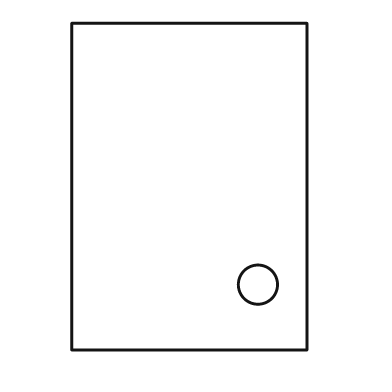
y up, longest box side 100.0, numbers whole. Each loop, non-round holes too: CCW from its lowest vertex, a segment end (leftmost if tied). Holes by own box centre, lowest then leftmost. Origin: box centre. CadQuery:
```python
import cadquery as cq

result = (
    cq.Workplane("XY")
    .moveTo(-36.0, -50.0)
    .lineTo(36.0, -50.0)
    .lineTo(36.0, 50.0)
    .lineTo(-36.0, 50.0)
    .close()
    .moveTo(21.0, -30.0)
    .circle(6.0)
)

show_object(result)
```